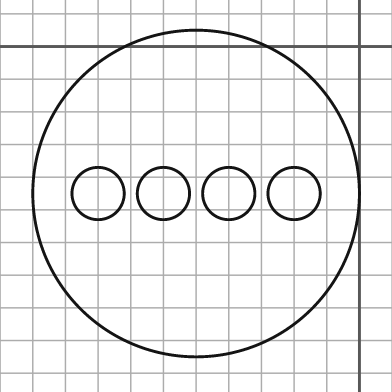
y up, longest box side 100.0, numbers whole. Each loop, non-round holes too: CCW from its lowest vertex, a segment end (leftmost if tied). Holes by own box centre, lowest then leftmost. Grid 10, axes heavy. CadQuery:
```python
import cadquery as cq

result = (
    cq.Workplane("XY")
    .moveTo(-50.0, -45.0)
    .circle(50.0)
    .moveTo(-80.0, -45.0)
    .circle(8.0)
    .moveTo(-60.0, -45.0)
    .circle(8.0)
    .moveTo(-40.0, -45.0)
    .circle(8.0)
    .moveTo(-20.0, -45.0)
    .circle(8.0)
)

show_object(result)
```